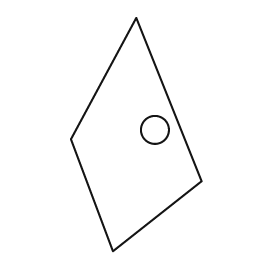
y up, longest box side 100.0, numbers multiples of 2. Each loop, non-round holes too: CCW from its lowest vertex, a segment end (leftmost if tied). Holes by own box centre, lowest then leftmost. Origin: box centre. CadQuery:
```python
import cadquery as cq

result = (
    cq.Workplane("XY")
    .moveTo(-10.0, -50.0)
    .lineTo(28.0, -20.0)
    .lineTo(0.0, 50.0)
    .lineTo(-28.0, -2.0)
    .close()
    .moveTo(8.0, 2.0)
    .circle(6.0)
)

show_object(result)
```